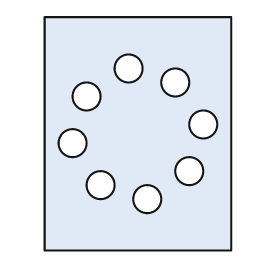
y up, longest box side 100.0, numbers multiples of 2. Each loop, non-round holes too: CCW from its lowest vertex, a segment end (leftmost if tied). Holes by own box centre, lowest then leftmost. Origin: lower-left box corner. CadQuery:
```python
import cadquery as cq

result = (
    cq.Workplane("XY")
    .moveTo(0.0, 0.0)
    .lineTo(80.0, 0.0)
    .lineTo(80.0, 100.0)
    .lineTo(0.0, 100.0)
    .close()
    .moveTo(44.0, 22.0)
    .circle(6.0)
    .moveTo(24.0, 28.0)
    .circle(6.0)
    .moveTo(62.0, 34.0)
    .circle(6.0)
    .moveTo(12.0, 46.0)
    .circle(6.0)
    .moveTo(68.0, 54.0)
    .circle(6.0)
    .moveTo(18.0, 66.0)
    .circle(6.0)
    .moveTo(56.0, 72.0)
    .circle(6.0)
    .moveTo(36.0, 78.0)
    .circle(6.0)
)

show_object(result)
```